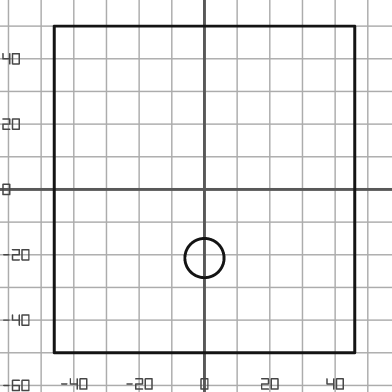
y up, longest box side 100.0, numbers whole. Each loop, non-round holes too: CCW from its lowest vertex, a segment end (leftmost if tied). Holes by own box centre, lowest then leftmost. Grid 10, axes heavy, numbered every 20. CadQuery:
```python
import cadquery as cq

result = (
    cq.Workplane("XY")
    .moveTo(-46.0, -50.0)
    .lineTo(46.0, -50.0)
    .lineTo(46.0, 50.0)
    .lineTo(-46.0, 50.0)
    .close()
    .moveTo(0.0, -21.0)
    .circle(6.0)
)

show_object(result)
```